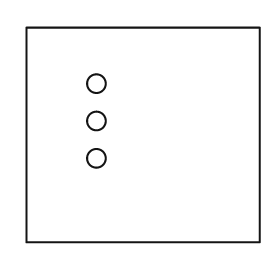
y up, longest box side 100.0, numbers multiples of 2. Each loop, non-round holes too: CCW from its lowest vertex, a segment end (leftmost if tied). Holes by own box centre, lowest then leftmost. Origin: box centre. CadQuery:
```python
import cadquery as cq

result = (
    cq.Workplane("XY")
    .moveTo(-50.0, -46.0)
    .lineTo(50.0, -46.0)
    .lineTo(50.0, 46.0)
    .lineTo(-50.0, 46.0)
    .close()
    .moveTo(-20.0, -10.0)
    .circle(4.0)
    .moveTo(-20.0, 6.0)
    .circle(4.0)
    .moveTo(-20.0, 22.0)
    .circle(4.0)
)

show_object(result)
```